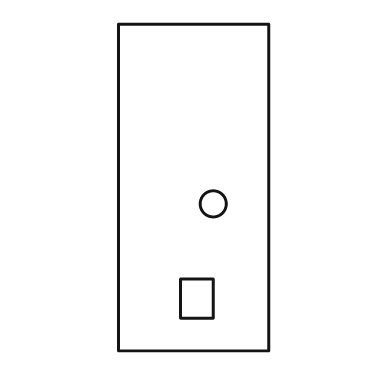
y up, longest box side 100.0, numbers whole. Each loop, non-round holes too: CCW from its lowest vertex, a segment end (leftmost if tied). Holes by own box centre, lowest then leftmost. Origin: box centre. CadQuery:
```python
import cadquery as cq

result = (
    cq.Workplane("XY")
    .moveTo(-23.0, -50.0)
    .lineTo(23.0, -50.0)
    .lineTo(23.0, 50.0)
    .lineTo(-23.0, 50.0)
    .close()
    .moveTo(-4.0, -40.0)
    .lineTo(6.0, -40.0)
    .lineTo(6.0, -28.0)
    .lineTo(-4.0, -28.0)
    .close()
    .moveTo(6.0, -5.0)
    .circle(4.0)
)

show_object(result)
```